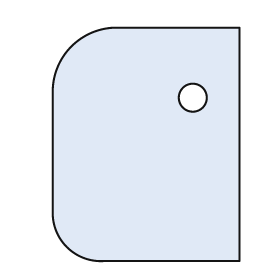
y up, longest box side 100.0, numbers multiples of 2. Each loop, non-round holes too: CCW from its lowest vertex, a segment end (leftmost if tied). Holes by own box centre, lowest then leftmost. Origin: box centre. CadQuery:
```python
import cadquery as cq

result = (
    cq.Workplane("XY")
    .moveTo(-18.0, -50.0)
    .lineTo(40.0, -50.0)
    .lineTo(40.0, 50.0)
    .lineTo(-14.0, 50.0)
    .threePointArc((-32.0, 42.0), (-40.0, 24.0))
    .lineTo(-40.0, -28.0)
    .threePointArc((-34.0, -44.0), (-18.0, -50.0))
    .close()
    .moveTo(20.0, 20.0)
    .circle(6.0)
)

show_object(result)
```